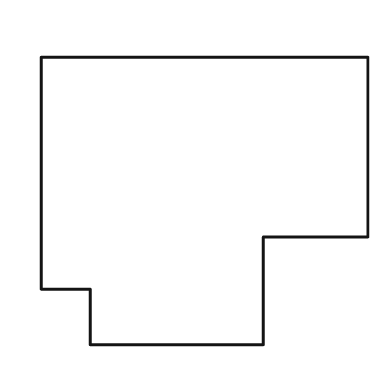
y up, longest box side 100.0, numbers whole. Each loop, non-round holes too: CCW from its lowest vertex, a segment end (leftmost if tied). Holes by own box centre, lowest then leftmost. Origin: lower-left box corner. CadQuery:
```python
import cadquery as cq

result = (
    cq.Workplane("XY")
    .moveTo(15.0, 0.0)
    .lineTo(68.0, 0.0)
    .lineTo(68.0, 33.0)
    .lineTo(100.0, 33.0)
    .lineTo(100.0, 88.0)
    .lineTo(0.0, 88.0)
    .lineTo(0.0, 17.0)
    .lineTo(15.0, 17.0)
    .close()
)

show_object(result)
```